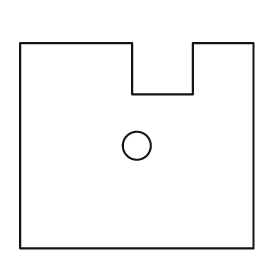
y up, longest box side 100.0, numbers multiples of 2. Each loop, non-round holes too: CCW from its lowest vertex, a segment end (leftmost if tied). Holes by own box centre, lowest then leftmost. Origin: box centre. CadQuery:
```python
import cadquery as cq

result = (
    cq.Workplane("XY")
    .moveTo(-50.0, -44.0)
    .lineTo(50.0, -44.0)
    .lineTo(50.0, 44.0)
    .lineTo(24.0, 44.0)
    .lineTo(24.0, 22.0)
    .lineTo(-2.0, 22.0)
    .lineTo(-2.0, 44.0)
    .lineTo(-50.0, 44.0)
    .close()
    .moveTo(0.0, 0.0)
    .circle(6.0)
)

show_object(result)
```